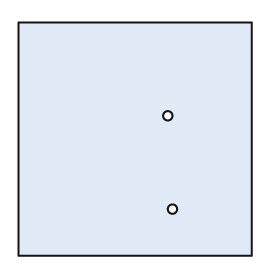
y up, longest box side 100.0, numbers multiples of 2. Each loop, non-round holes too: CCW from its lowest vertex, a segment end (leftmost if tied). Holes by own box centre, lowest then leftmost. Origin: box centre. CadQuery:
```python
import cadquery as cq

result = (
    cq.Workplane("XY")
    .moveTo(-50.0, -50.0)
    .lineTo(50.0, -50.0)
    .lineTo(50.0, 50.0)
    .lineTo(-50.0, 50.0)
    .close()
    .moveTo(16.0, -30.0)
    .circle(2.0)
    .moveTo(14.0, 10.0)
    .circle(2.0)
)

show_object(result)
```